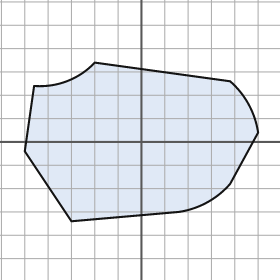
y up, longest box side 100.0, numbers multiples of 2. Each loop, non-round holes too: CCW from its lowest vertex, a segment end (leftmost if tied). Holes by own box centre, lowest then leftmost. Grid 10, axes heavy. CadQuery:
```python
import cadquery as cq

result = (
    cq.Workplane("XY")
    .moveTo(-30.0, -34.0)
    .lineTo(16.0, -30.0)
    .threePointArc((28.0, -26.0), (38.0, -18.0))
    .lineTo(50.0, 4.0)
    .threePointArc((46.0, 16.0), (38.0, 26.0))
    .lineTo(-20.0, 34.0)
    .threePointArc((-32.0, 26.0), (-46.0, 24.0))
    .lineTo(-50.0, -4.0)
    .close()
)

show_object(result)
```